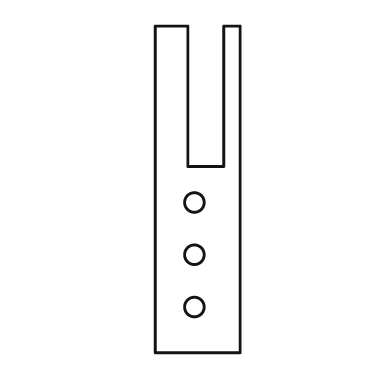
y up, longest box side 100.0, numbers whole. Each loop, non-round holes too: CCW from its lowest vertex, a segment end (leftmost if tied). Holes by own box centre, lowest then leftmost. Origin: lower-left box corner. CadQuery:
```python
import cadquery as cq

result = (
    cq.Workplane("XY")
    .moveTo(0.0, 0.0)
    .lineTo(26.0, 0.0)
    .lineTo(26.0, 100.0)
    .lineTo(21.0, 100.0)
    .lineTo(21.0, 57.0)
    .lineTo(10.0, 57.0)
    .lineTo(10.0, 100.0)
    .lineTo(0.0, 100.0)
    .close()
    .moveTo(12.0, 14.0)
    .circle(3.0)
    .moveTo(12.0, 30.0)
    .circle(3.0)
    .moveTo(12.0, 46.0)
    .circle(3.0)
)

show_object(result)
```